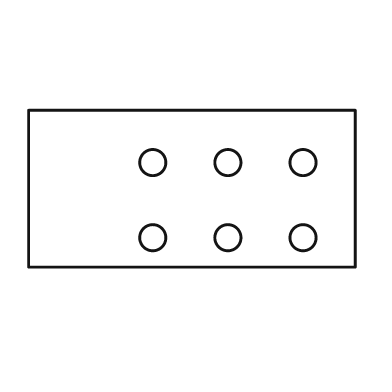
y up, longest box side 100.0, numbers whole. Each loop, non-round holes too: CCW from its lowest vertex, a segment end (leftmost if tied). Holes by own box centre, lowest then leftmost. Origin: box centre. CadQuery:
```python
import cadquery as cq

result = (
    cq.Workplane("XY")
    .moveTo(-50.0, -24.0)
    .lineTo(50.0, -24.0)
    .lineTo(50.0, 24.0)
    .lineTo(-50.0, 24.0)
    .close()
    .moveTo(-12.0, -15.0)
    .circle(4.0)
    .moveTo(11.0, -15.0)
    .circle(4.0)
    .moveTo(34.0, -15.0)
    .circle(4.0)
    .moveTo(-12.0, 8.0)
    .circle(4.0)
    .moveTo(11.0, 8.0)
    .circle(4.0)
    .moveTo(34.0, 8.0)
    .circle(4.0)
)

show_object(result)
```